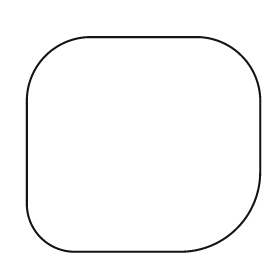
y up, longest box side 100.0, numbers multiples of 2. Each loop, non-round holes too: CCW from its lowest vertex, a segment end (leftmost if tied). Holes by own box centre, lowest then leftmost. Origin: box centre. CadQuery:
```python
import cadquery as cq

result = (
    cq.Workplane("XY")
    .moveTo(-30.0, -46.0)
    .lineTo(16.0, -46.0)
    .threePointArc((40.0, -36.0), (50.0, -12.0))
    .lineTo(50.0, 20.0)
    .threePointArc((42.0, 38.0), (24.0, 46.0))
    .lineTo(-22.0, 46.0)
    .threePointArc((-42.0, 38.0), (-50.0, 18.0))
    .lineTo(-50.0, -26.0)
    .threePointArc((-44.0, -40.0), (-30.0, -46.0))
    .close()
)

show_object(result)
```